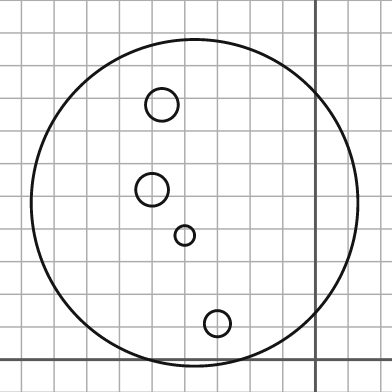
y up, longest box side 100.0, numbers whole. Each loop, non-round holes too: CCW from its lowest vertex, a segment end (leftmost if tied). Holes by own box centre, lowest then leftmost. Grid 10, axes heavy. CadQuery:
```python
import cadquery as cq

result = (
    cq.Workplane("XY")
    .moveTo(-37.0, 48.0)
    .circle(50.0)
    .moveTo(-30.0, 11.0)
    .circle(4.0)
    .moveTo(-40.0, 38.0)
    .circle(3.0)
    .moveTo(-50.0, 52.0)
    .circle(5.0)
    .moveTo(-47.0, 78.0)
    .circle(5.0)
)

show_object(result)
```